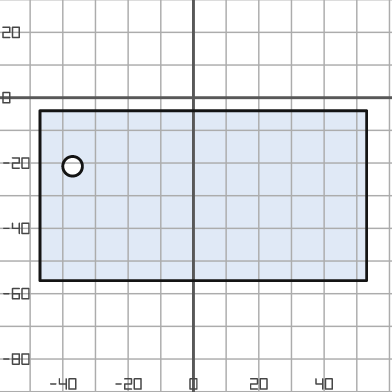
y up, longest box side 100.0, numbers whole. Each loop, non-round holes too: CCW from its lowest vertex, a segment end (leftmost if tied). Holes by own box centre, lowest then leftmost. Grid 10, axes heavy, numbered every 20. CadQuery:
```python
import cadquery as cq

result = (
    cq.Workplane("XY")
    .moveTo(-47.0, -56.0)
    .lineTo(53.0, -56.0)
    .lineTo(53.0, -4.0)
    .lineTo(-47.0, -4.0)
    .close()
    .moveTo(-37.0, -21.0)
    .circle(3.0)
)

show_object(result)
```